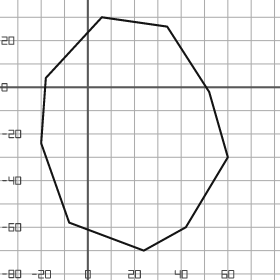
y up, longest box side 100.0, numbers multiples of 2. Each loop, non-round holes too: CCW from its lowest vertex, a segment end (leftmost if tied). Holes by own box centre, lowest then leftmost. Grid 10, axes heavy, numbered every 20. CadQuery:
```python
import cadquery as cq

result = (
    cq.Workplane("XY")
    .moveTo(24.0, -70.0)
    .lineTo(42.0, -60.0)
    .lineTo(60.0, -30.0)
    .lineTo(52.0, -2.0)
    .lineTo(34.0, 26.0)
    .lineTo(6.0, 30.0)
    .lineTo(-18.0, 4.0)
    .lineTo(-20.0, -24.0)
    .lineTo(-8.0, -58.0)
    .close()
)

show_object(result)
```